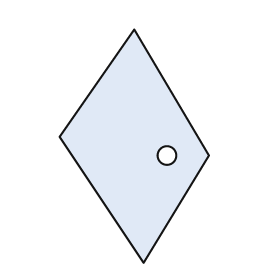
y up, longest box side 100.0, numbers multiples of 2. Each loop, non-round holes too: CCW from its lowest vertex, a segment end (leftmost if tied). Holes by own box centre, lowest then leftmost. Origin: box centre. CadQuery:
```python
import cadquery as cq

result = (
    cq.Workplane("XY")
    .moveTo(4.0, -50.0)
    .lineTo(32.0, -4.0)
    .lineTo(0.0, 50.0)
    .lineTo(-32.0, 4.0)
    .close()
    .moveTo(14.0, -4.0)
    .circle(4.0)
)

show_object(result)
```